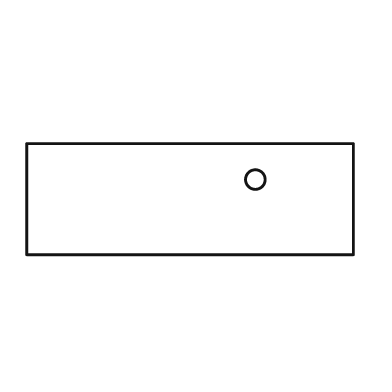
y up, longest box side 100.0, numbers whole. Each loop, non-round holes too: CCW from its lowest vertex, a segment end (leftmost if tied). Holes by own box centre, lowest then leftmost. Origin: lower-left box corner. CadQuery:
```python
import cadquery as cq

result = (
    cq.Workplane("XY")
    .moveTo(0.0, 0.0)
    .lineTo(100.0, 0.0)
    .lineTo(100.0, 34.0)
    .lineTo(0.0, 34.0)
    .close()
    .moveTo(70.0, 23.0)
    .circle(3.0)
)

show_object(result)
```